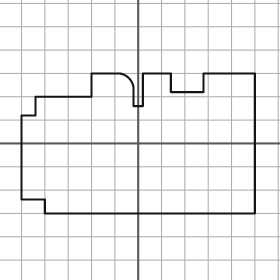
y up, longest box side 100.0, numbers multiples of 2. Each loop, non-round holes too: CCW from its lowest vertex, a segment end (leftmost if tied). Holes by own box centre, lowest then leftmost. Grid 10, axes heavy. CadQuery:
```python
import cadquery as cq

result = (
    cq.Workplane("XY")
    .moveTo(-40.0, -30.0)
    .lineTo(50.0, -30.0)
    .lineTo(50.0, 30.0)
    .lineTo(28.0, 30.0)
    .lineTo(28.0, 22.0)
    .lineTo(14.0, 22.0)
    .lineTo(14.0, 30.0)
    .lineTo(2.0, 30.0)
    .lineTo(2.0, 16.0)
    .lineTo(-2.0, 16.0)
    .lineTo(-2.0, 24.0)
    .threePointArc((-4.0, 28.0), (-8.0, 30.0))
    .lineTo(-20.0, 30.0)
    .lineTo(-20.0, 20.0)
    .lineTo(-44.0, 20.0)
    .lineTo(-44.0, 12.0)
    .lineTo(-50.0, 12.0)
    .lineTo(-50.0, -24.0)
    .lineTo(-40.0, -24.0)
    .close()
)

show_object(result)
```